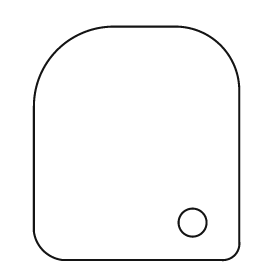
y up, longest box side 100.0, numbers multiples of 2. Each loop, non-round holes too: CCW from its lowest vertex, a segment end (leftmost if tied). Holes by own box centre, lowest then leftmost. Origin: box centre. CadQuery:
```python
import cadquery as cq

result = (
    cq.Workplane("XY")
    .moveTo(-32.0, -50.0)
    .lineTo(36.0, -50.0)
    .threePointArc((42.0, -48.0), (44.0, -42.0))
    .lineTo(44.0, 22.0)
    .threePointArc((36.0, 42.0), (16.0, 50.0))
    .lineTo(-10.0, 50.0)
    .threePointArc((-34.0, 40.0), (-44.0, 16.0))
    .lineTo(-44.0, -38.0)
    .threePointArc((-40.0, -46.0), (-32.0, -50.0))
    .close()
    .moveTo(24.0, -34.0)
    .circle(6.0)
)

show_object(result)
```